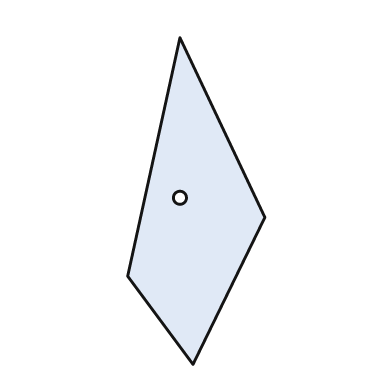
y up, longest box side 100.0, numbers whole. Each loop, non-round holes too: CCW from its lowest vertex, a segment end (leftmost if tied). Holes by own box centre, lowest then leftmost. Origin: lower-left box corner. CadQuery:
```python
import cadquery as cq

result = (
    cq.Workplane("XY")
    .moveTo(20.0, 0.0)
    .lineTo(42.0, 45.0)
    .lineTo(16.0, 100.0)
    .lineTo(0.0, 27.0)
    .close()
    .moveTo(16.0, 51.0)
    .circle(2.0)
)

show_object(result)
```